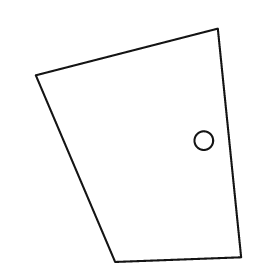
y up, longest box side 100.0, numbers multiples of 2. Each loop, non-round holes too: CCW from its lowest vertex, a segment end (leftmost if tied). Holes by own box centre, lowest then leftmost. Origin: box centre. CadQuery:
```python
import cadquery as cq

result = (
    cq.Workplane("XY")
    .moveTo(-10.0, -50.0)
    .lineTo(44.0, -48.0)
    .lineTo(34.0, 50.0)
    .lineTo(-44.0, 30.0)
    .close()
    .moveTo(28.0, 2.0)
    .circle(4.0)
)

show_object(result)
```